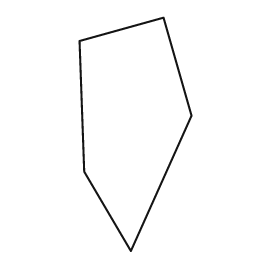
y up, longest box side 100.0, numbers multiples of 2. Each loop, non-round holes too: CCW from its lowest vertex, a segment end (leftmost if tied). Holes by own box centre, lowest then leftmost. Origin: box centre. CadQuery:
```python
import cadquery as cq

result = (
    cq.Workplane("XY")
    .moveTo(-2.0, -50.0)
    .lineTo(24.0, 8.0)
    .lineTo(12.0, 50.0)
    .lineTo(-24.0, 40.0)
    .lineTo(-22.0, -16.0)
    .close()
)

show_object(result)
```